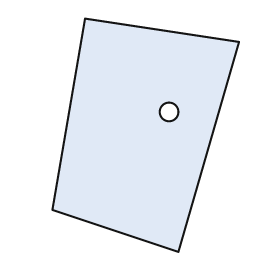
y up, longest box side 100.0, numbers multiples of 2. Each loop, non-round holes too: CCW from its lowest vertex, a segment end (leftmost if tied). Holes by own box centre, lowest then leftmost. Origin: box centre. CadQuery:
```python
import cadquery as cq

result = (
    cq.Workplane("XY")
    .moveTo(14.0, -50.0)
    .lineTo(40.0, 40.0)
    .lineTo(-26.0, 50.0)
    .lineTo(-40.0, -32.0)
    .close()
    .moveTo(10.0, 10.0)
    .circle(4.0)
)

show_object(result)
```